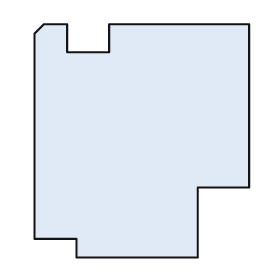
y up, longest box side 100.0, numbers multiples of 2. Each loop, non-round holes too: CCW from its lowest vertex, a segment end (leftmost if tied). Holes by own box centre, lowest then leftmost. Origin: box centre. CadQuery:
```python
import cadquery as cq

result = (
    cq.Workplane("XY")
    .moveTo(-28.0, -50.0)
    .lineTo(24.0, -50.0)
    .lineTo(24.0, -20.0)
    .lineTo(46.0, -20.0)
    .lineTo(46.0, 50.0)
    .lineTo(-14.0, 50.0)
    .lineTo(-14.0, 38.0)
    .lineTo(-32.0, 38.0)
    .lineTo(-32.0, 50.0)
    .lineTo(-42.0, 50.0)
    .lineTo(-46.0, 46.0)
    .lineTo(-46.0, -42.0)
    .lineTo(-28.0, -42.0)
    .close()
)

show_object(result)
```